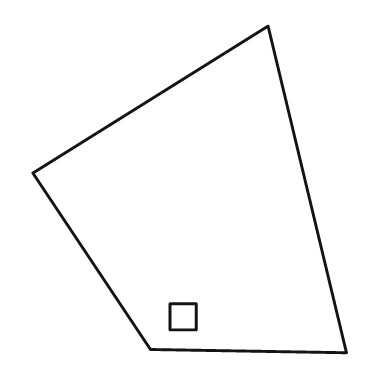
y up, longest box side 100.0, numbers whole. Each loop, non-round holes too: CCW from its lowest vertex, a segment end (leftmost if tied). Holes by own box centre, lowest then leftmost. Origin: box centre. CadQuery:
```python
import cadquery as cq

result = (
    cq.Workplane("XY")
    .moveTo(48.0, -50.0)
    .lineTo(24.0, 50.0)
    .lineTo(-48.0, 5.0)
    .lineTo(-12.0, -49.0)
    .close()
    .moveTo(-6.0, -43.0)
    .lineTo(2.0, -43.0)
    .lineTo(2.0, -35.0)
    .lineTo(-6.0, -35.0)
    .close()
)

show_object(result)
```